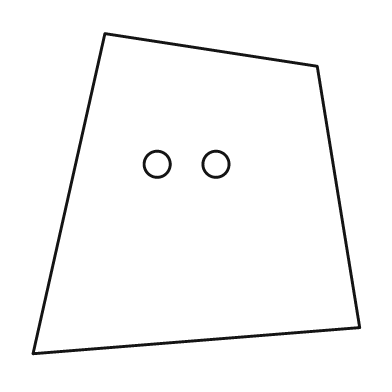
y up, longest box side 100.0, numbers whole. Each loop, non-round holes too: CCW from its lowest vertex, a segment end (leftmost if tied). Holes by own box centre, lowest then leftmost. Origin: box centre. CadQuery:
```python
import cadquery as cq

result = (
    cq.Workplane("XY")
    .moveTo(-50.0, -49.0)
    .lineTo(50.0, -41.0)
    .lineTo(37.0, 39.0)
    .lineTo(-28.0, 49.0)
    .close()
    .moveTo(-12.0, 9.0)
    .circle(4.0)
    .moveTo(6.0, 9.0)
    .circle(4.0)
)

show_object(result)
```